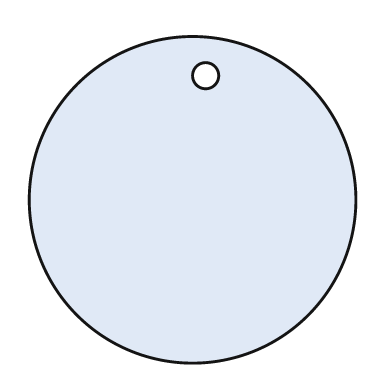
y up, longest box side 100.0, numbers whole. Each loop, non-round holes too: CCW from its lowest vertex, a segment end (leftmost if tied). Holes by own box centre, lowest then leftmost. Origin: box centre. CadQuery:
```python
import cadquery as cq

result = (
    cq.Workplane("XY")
    .moveTo(0.0, 0.0)
    .circle(50.0)
    .moveTo(4.0, 38.0)
    .circle(4.0)
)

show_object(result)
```